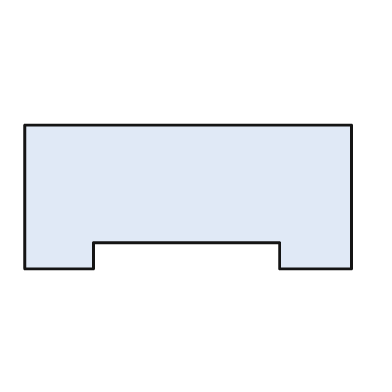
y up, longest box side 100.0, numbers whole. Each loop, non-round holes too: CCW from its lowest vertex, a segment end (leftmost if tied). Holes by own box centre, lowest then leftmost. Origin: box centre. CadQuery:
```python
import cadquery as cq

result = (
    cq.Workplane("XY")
    .moveTo(-50.0, -22.0)
    .lineTo(-29.0, -22.0)
    .lineTo(-29.0, -14.0)
    .lineTo(28.0, -14.0)
    .lineTo(28.0, -22.0)
    .lineTo(50.0, -22.0)
    .lineTo(50.0, 22.0)
    .lineTo(-50.0, 22.0)
    .close()
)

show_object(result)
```